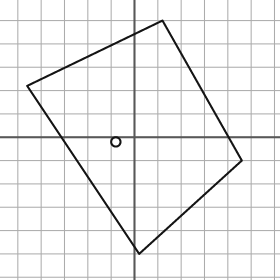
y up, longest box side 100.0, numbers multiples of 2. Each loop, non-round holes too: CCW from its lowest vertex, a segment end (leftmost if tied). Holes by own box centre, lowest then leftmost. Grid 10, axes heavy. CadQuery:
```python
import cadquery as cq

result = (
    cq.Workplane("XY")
    .moveTo(2.0, -50.0)
    .lineTo(46.0, -10.0)
    .lineTo(12.0, 50.0)
    .lineTo(-46.0, 22.0)
    .close()
    .moveTo(-8.0, -2.0)
    .circle(2.0)
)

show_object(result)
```